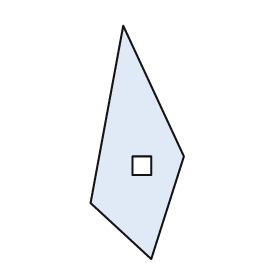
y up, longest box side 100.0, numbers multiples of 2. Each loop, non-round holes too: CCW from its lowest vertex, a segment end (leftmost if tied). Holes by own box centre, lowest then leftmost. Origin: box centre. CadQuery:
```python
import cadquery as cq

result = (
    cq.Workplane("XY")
    .moveTo(6.0, -50.0)
    .lineTo(20.0, -6.0)
    .lineTo(-6.0, 50.0)
    .lineTo(-20.0, -26.0)
    .close()
    .moveTo(-2.0, -14.0)
    .lineTo(6.0, -14.0)
    .lineTo(6.0, -6.0)
    .lineTo(-2.0, -6.0)
    .close()
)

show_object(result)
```